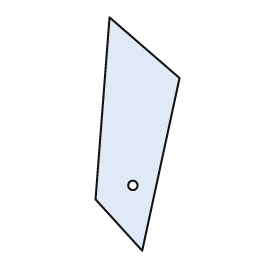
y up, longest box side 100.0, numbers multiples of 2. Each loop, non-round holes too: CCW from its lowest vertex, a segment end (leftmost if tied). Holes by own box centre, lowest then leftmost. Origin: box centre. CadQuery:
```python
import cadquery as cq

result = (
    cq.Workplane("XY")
    .moveTo(2.0, -50.0)
    .lineTo(18.0, 24.0)
    .lineTo(-12.0, 50.0)
    .lineTo(-18.0, -28.0)
    .close()
    .moveTo(-2.0, -22.0)
    .circle(2.0)
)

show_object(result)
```